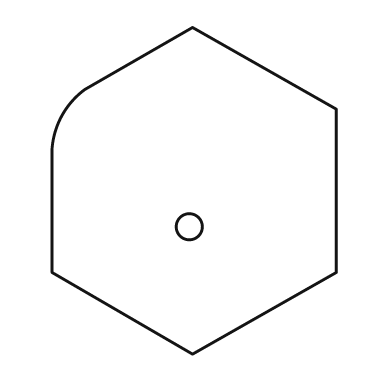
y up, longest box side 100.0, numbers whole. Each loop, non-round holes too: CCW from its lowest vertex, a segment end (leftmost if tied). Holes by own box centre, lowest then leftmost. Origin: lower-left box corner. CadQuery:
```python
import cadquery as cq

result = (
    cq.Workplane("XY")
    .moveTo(43.0, 0.0)
    .lineTo(87.0, 25.0)
    .lineTo(87.0, 75.0)
    .lineTo(43.0, 100.0)
    .lineTo(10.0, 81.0)
    .threePointArc((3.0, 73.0), (0.0, 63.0))
    .lineTo(0.0, 25.0)
    .close()
    .moveTo(42.0, 39.0)
    .circle(4.0)
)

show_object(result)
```